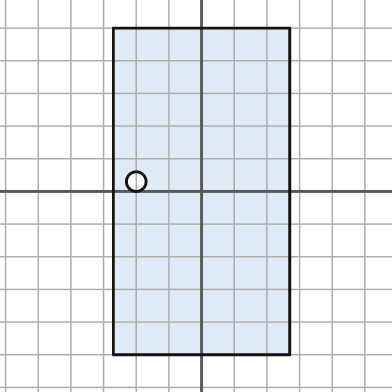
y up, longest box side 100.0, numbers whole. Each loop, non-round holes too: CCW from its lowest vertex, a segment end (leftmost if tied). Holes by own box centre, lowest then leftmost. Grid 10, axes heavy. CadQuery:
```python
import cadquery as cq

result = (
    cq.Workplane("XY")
    .moveTo(-27.0, -50.0)
    .lineTo(27.0, -50.0)
    .lineTo(27.0, 50.0)
    .lineTo(-27.0, 50.0)
    .close()
    .moveTo(-20.0, 3.0)
    .circle(3.0)
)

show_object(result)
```